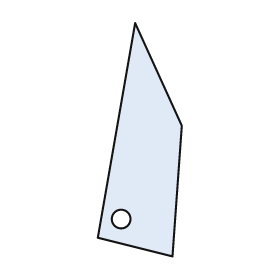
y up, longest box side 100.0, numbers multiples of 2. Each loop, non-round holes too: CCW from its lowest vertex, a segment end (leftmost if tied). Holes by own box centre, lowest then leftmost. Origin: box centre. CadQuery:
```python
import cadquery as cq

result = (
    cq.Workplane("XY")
    .moveTo(14.0, -50.0)
    .lineTo(18.0, 6.0)
    .lineTo(-2.0, 50.0)
    .lineTo(-18.0, -42.0)
    .close()
    .moveTo(-8.0, -34.0)
    .circle(4.0)
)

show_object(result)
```